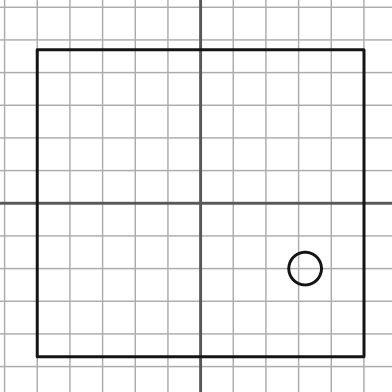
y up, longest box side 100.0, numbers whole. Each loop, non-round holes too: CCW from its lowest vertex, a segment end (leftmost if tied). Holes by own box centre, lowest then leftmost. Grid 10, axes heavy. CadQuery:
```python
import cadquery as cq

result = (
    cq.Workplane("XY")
    .moveTo(-50.0, -47.0)
    .lineTo(50.0, -47.0)
    .lineTo(50.0, 47.0)
    .lineTo(-50.0, 47.0)
    .close()
    .moveTo(32.0, -20.0)
    .circle(5.0)
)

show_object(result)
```